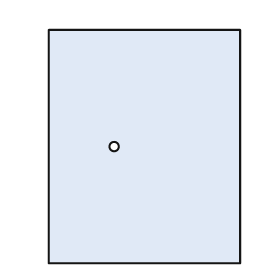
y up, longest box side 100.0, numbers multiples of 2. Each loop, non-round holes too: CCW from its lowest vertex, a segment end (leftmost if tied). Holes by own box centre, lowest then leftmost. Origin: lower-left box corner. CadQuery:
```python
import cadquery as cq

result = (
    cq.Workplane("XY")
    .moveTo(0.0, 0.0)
    .lineTo(82.0, 0.0)
    .lineTo(82.0, 100.0)
    .lineTo(0.0, 100.0)
    .close()
    .moveTo(28.0, 50.0)
    .circle(2.0)
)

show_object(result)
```